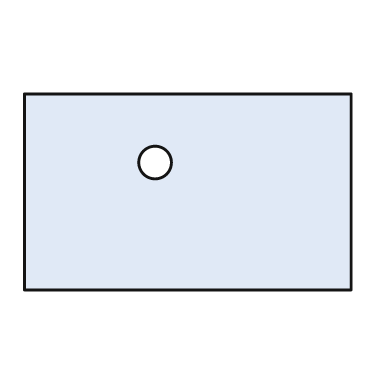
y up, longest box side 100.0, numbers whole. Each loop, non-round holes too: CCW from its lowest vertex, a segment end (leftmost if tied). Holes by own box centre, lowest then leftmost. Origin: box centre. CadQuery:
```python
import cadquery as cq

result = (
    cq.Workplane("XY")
    .moveTo(-50.0, -30.0)
    .lineTo(50.0, -30.0)
    .lineTo(50.0, 30.0)
    .lineTo(-50.0, 30.0)
    .close()
    .moveTo(-10.0, 9.0)
    .circle(5.0)
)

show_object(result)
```